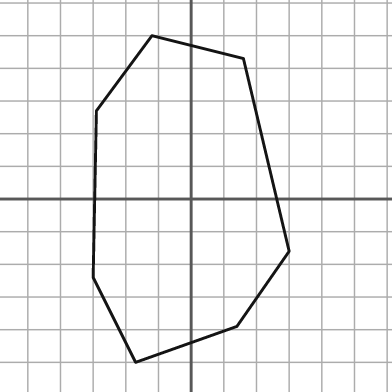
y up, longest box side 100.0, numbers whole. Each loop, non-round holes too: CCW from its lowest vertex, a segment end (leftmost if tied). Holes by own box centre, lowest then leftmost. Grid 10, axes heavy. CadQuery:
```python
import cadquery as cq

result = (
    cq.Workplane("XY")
    .moveTo(-17.0, -50.0)
    .lineTo(14.0, -39.0)
    .lineTo(30.0, -16.0)
    .lineTo(16.0, 43.0)
    .lineTo(-12.0, 50.0)
    .lineTo(-29.0, 27.0)
    .lineTo(-30.0, -24.0)
    .close()
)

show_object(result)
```